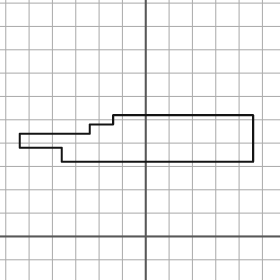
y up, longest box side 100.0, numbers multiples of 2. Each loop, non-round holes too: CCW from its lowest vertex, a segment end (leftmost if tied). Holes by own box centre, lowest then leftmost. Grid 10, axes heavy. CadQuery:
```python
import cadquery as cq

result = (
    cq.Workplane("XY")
    .moveTo(-36.0, 32.0)
    .lineTo(46.0, 32.0)
    .lineTo(46.0, 52.0)
    .lineTo(-14.0, 52.0)
    .lineTo(-14.0, 48.0)
    .lineTo(-24.0, 48.0)
    .lineTo(-24.0, 44.0)
    .lineTo(-54.0, 44.0)
    .lineTo(-54.0, 38.0)
    .lineTo(-36.0, 38.0)
    .close()
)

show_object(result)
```